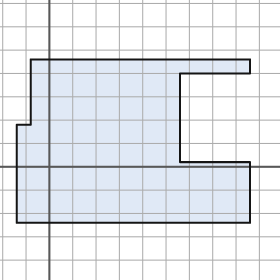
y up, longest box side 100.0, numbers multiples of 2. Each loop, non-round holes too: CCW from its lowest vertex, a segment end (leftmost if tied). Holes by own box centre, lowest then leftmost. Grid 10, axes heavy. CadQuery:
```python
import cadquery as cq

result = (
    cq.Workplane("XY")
    .moveTo(-14.0, -24.0)
    .lineTo(86.0, -24.0)
    .lineTo(86.0, 2.0)
    .lineTo(56.0, 2.0)
    .lineTo(56.0, 40.0)
    .lineTo(86.0, 40.0)
    .lineTo(86.0, 46.0)
    .lineTo(-8.0, 46.0)
    .lineTo(-8.0, 18.0)
    .lineTo(-14.0, 18.0)
    .close()
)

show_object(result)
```